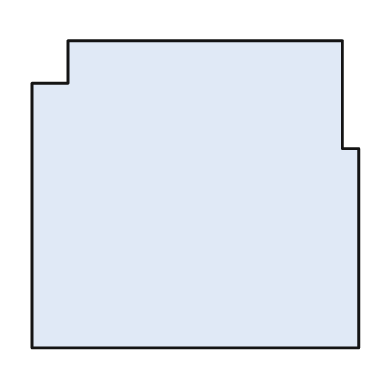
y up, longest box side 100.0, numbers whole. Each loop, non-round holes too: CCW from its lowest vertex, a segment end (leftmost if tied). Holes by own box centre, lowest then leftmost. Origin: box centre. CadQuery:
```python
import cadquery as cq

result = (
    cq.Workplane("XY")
    .moveTo(-50.0, -47.0)
    .lineTo(50.0, -47.0)
    .lineTo(50.0, 14.0)
    .lineTo(45.0, 14.0)
    .lineTo(45.0, 47.0)
    .lineTo(-39.0, 47.0)
    .lineTo(-39.0, 34.0)
    .lineTo(-50.0, 34.0)
    .close()
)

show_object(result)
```